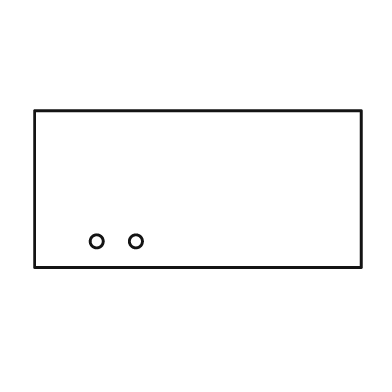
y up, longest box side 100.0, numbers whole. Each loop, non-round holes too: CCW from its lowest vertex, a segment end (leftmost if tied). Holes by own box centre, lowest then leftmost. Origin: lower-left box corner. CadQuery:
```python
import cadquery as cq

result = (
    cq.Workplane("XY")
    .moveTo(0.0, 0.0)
    .lineTo(100.0, 0.0)
    .lineTo(100.0, 48.0)
    .lineTo(0.0, 48.0)
    .close()
    .moveTo(19.0, 8.0)
    .circle(2.0)
    .moveTo(31.0, 8.0)
    .circle(2.0)
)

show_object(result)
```